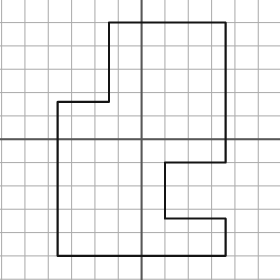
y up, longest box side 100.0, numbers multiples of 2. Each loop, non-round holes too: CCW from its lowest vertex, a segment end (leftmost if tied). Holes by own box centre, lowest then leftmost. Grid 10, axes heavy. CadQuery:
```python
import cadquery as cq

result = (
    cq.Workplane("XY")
    .moveTo(-36.0, -50.0)
    .lineTo(36.0, -50.0)
    .lineTo(36.0, -34.0)
    .lineTo(10.0, -34.0)
    .lineTo(10.0, -10.0)
    .lineTo(36.0, -10.0)
    .lineTo(36.0, 50.0)
    .lineTo(-14.0, 50.0)
    .lineTo(-14.0, 16.0)
    .lineTo(-36.0, 16.0)
    .close()
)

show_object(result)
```